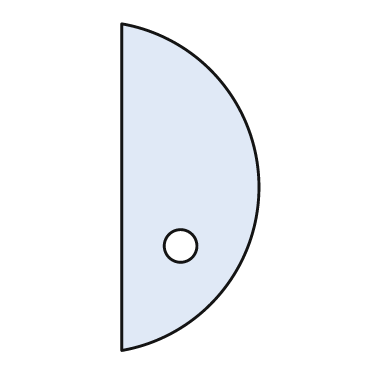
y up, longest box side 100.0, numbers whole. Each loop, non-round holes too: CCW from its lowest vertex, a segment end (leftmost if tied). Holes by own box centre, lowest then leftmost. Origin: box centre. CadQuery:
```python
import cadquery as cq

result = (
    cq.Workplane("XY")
    .moveTo(-21.0, -50.0)
    .threePointArc((21.0, 0.0), (-21.0, 50.0))
    .close()
    .moveTo(-3.0, -18.0)
    .circle(5.0)
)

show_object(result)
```